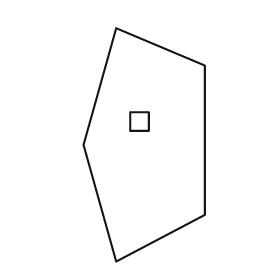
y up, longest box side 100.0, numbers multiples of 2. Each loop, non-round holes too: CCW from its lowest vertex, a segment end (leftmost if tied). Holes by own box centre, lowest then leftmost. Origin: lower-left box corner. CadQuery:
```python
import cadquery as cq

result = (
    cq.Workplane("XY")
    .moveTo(14.0, 0.0)
    .lineTo(52.0, 20.0)
    .lineTo(52.0, 84.0)
    .lineTo(14.0, 100.0)
    .lineTo(0.0, 50.0)
    .close()
    .moveTo(20.0, 56.0)
    .lineTo(28.0, 56.0)
    .lineTo(28.0, 64.0)
    .lineTo(20.0, 64.0)
    .close()
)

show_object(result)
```